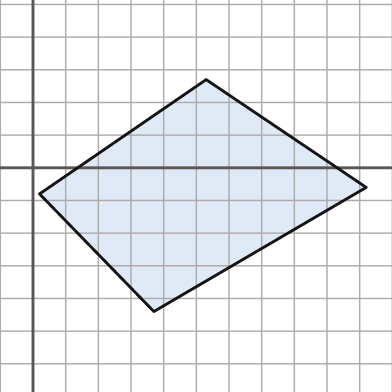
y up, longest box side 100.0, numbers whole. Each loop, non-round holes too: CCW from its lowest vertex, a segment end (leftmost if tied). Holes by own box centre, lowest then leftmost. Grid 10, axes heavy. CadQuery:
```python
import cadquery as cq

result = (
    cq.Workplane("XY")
    .moveTo(37.0, -44.0)
    .lineTo(102.0, -6.0)
    .lineTo(53.0, 27.0)
    .lineTo(2.0, -8.0)
    .close()
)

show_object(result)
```